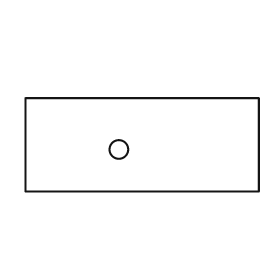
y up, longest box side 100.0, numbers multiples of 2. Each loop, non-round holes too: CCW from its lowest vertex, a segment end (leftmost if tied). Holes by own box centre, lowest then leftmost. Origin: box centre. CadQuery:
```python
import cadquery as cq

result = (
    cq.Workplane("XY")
    .moveTo(-50.0, -20.0)
    .lineTo(50.0, -20.0)
    .lineTo(50.0, 20.0)
    .lineTo(-50.0, 20.0)
    .close()
    .moveTo(-10.0, -2.0)
    .circle(4.0)
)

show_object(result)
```